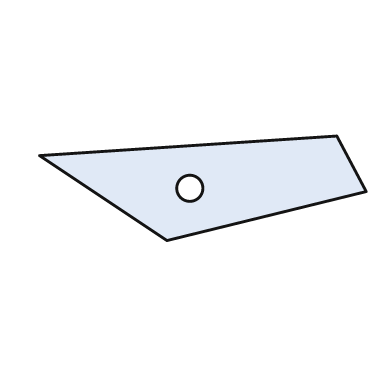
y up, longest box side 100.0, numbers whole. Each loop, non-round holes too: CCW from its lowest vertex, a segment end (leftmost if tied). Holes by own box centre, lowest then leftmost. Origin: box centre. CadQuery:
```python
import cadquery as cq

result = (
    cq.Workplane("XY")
    .moveTo(-11.0, -16.0)
    .lineTo(50.0, -1.0)
    .lineTo(41.0, 16.0)
    .lineTo(-50.0, 10.0)
    .close()
    .moveTo(-4.0, 0.0)
    .circle(4.0)
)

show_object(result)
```